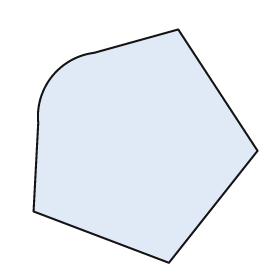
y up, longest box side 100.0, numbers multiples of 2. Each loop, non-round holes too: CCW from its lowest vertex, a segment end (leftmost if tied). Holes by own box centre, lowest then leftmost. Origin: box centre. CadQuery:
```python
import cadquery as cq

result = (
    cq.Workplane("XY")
    .moveTo(10.0, -50.0)
    .lineTo(48.0, -2.0)
    .lineTo(14.0, 50.0)
    .lineTo(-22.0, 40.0)
    .threePointArc((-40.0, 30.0), (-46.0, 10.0))
    .lineTo(-48.0, -28.0)
    .close()
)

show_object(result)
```